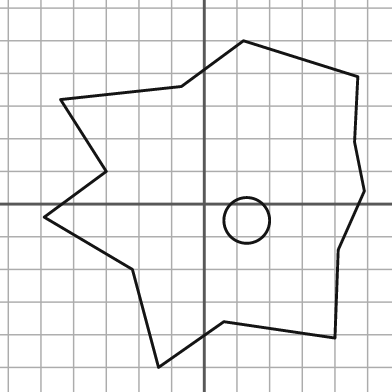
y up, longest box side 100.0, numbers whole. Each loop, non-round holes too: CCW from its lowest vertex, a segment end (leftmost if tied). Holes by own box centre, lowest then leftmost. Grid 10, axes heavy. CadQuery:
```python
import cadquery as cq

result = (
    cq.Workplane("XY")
    .moveTo(-14.0, -50.0)
    .lineTo(6.0, -36.0)
    .lineTo(40.0, -41.0)
    .lineTo(41.0, -14.0)
    .lineTo(49.0, 4.0)
    .lineTo(46.0, 19.0)
    .lineTo(47.0, 39.0)
    .lineTo(12.0, 50.0)
    .lineTo(-7.0, 36.0)
    .lineTo(-44.0, 32.0)
    .lineTo(-30.0, 10.0)
    .lineTo(-49.0, -4.0)
    .lineTo(-22.0, -20.0)
    .close()
    .moveTo(13.0, -5.0)
    .circle(7.0)
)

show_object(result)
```